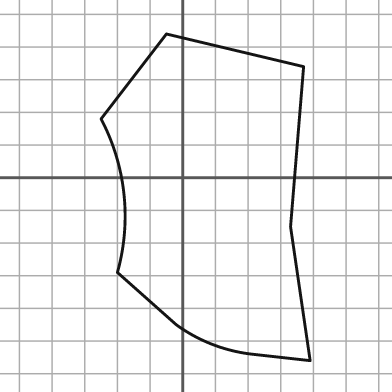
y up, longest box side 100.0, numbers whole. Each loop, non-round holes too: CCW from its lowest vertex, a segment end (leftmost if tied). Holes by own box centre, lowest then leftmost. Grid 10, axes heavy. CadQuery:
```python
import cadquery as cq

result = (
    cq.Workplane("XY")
    .moveTo(39.0, -56.0)
    .lineTo(33.0, -15.0)
    .lineTo(37.0, 34.0)
    .lineTo(-5.0, 44.0)
    .lineTo(-25.0, 18.0)
    .threePointArc((-18.0, -5.0), (-20.0, -29.0))
    .lineTo(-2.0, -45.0)
    .threePointArc((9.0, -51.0), (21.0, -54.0))
    .close()
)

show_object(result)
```